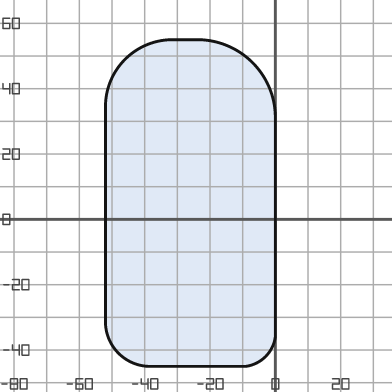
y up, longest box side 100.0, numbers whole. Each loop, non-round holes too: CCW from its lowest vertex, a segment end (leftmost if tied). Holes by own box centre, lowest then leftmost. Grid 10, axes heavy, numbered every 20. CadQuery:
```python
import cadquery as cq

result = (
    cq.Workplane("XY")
    .moveTo(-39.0, -45.0)
    .lineTo(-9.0, -45.0)
    .threePointArc((-3.0, -42.0), (0.0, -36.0))
    .lineTo(0.0, 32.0)
    .threePointArc((-7.0, 48.0), (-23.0, 55.0))
    .lineTo(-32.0, 55.0)
    .threePointArc((-46.0, 49.0), (-52.0, 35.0))
    .lineTo(-52.0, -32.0)
    .threePointArc((-48.0, -41.0), (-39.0, -45.0))
    .close()
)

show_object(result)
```